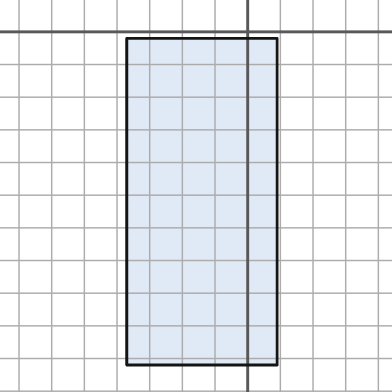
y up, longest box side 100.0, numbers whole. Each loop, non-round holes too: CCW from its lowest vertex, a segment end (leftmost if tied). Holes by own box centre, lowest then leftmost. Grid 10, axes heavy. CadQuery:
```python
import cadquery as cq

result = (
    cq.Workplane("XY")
    .moveTo(-37.0, -102.0)
    .lineTo(9.0, -102.0)
    .lineTo(9.0, -2.0)
    .lineTo(-37.0, -2.0)
    .close()
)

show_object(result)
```